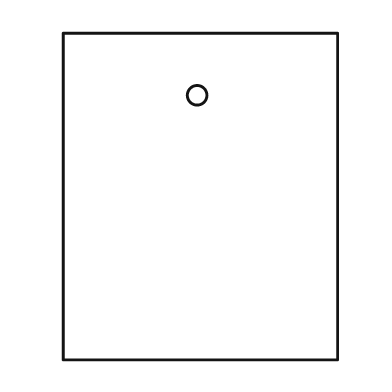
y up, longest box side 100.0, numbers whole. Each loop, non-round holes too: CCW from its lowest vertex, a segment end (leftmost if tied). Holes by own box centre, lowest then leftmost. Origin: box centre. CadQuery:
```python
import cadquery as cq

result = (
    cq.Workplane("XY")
    .moveTo(-42.0, -50.0)
    .lineTo(42.0, -50.0)
    .lineTo(42.0, 50.0)
    .lineTo(-42.0, 50.0)
    .close()
    .moveTo(-1.0, 31.0)
    .circle(3.0)
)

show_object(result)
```